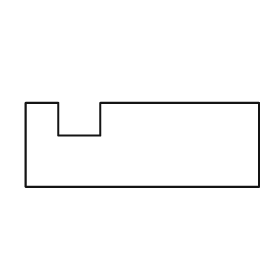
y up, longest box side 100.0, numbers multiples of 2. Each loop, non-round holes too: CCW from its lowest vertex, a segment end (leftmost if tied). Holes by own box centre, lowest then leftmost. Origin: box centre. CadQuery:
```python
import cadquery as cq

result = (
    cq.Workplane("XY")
    .moveTo(-50.0, -18.0)
    .lineTo(50.0, -18.0)
    .lineTo(50.0, 18.0)
    .lineTo(-18.0, 18.0)
    .lineTo(-18.0, 4.0)
    .lineTo(-36.0, 4.0)
    .lineTo(-36.0, 18.0)
    .lineTo(-50.0, 18.0)
    .close()
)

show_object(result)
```